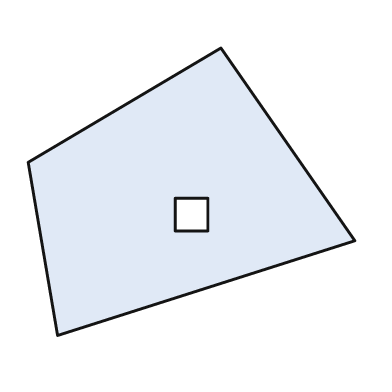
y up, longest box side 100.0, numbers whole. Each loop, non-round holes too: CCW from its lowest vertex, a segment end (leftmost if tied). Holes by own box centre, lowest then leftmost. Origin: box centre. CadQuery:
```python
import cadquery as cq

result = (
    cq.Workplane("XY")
    .moveTo(-41.0, -44.0)
    .lineTo(50.0, -15.0)
    .lineTo(9.0, 44.0)
    .lineTo(-50.0, 9.0)
    .close()
    .moveTo(-5.0, -12.0)
    .lineTo(5.0, -12.0)
    .lineTo(5.0, -2.0)
    .lineTo(-5.0, -2.0)
    .close()
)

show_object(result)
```